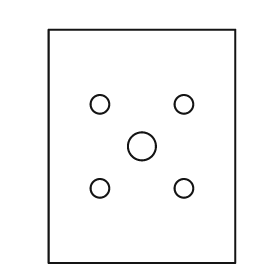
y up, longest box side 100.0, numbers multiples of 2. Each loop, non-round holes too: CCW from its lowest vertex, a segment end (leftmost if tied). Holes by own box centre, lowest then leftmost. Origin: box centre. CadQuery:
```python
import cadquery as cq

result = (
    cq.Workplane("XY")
    .moveTo(-40.0, -50.0)
    .lineTo(40.0, -50.0)
    .lineTo(40.0, 50.0)
    .lineTo(-40.0, 50.0)
    .close()
    .moveTo(-18.0, -18.0)
    .circle(4.0)
    .moveTo(18.0, -18.0)
    .circle(4.0)
    .moveTo(0.0, 0.0)
    .circle(6.0)
    .moveTo(-18.0, 18.0)
    .circle(4.0)
    .moveTo(18.0, 18.0)
    .circle(4.0)
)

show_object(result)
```